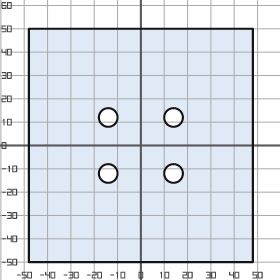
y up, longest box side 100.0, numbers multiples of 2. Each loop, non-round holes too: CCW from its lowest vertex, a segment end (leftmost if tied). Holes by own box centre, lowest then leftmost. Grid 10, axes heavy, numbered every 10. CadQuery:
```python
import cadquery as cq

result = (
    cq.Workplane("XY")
    .moveTo(-48.0, -50.0)
    .lineTo(48.0, -50.0)
    .lineTo(48.0, 50.0)
    .lineTo(-48.0, 50.0)
    .close()
    .moveTo(-14.0, -12.0)
    .circle(4.0)
    .moveTo(14.0, -12.0)
    .circle(4.0)
    .moveTo(-14.0, 12.0)
    .circle(4.0)
    .moveTo(14.0, 12.0)
    .circle(4.0)
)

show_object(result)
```